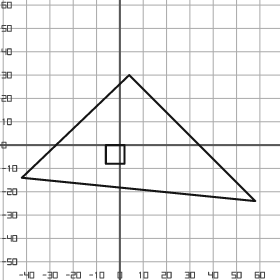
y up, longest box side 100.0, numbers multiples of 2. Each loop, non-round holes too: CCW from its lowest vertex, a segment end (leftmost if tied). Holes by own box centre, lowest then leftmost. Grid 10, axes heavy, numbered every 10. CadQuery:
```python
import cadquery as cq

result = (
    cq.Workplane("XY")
    .moveTo(58.0, -24.0)
    .lineTo(4.0, 30.0)
    .lineTo(-42.0, -14.0)
    .close()
    .moveTo(-6.0, -8.0)
    .lineTo(2.0, -8.0)
    .lineTo(2.0, 0.0)
    .lineTo(-6.0, 0.0)
    .close()
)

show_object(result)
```